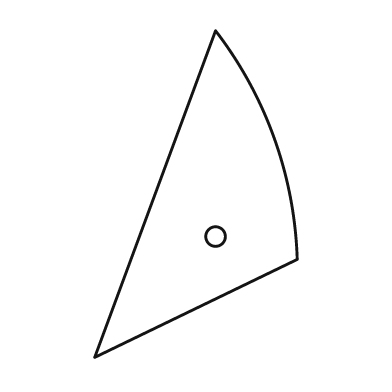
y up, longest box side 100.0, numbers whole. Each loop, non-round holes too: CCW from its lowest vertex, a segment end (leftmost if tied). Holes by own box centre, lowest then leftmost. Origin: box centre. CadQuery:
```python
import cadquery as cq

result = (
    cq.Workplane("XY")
    .moveTo(-31.0, -50.0)
    .lineTo(31.0, -20.0)
    .threePointArc((24.0, 17.0), (6.0, 50.0))
    .close()
    .moveTo(6.0, -13.0)
    .circle(3.0)
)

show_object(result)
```